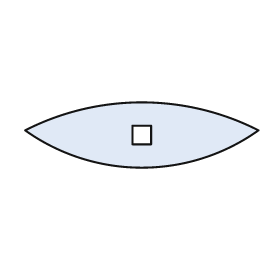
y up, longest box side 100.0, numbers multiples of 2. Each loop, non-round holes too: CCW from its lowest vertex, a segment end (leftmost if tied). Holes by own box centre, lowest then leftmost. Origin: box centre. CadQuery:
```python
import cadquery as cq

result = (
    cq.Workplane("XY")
    .moveTo(-50.0, 2.0)
    .threePointArc((0.0, -14.0), (50.0, 2.0))
    .threePointArc((0.0, 14.0), (-50.0, 2.0))
    .close()
    .moveTo(-4.0, -4.0)
    .lineTo(4.0, -4.0)
    .lineTo(4.0, 4.0)
    .lineTo(-4.0, 4.0)
    .close()
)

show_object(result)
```